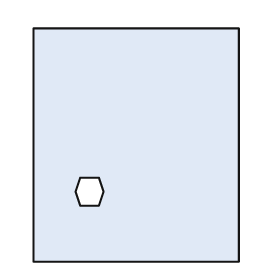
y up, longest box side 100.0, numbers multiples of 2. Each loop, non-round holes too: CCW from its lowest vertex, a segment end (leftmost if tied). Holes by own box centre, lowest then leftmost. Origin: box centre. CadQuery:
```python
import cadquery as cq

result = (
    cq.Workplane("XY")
    .moveTo(-44.0, -50.0)
    .lineTo(44.0, -50.0)
    .lineTo(44.0, 50.0)
    .lineTo(-44.0, 50.0)
    .close()
    .moveTo(-24.0, -26.0)
    .lineTo(-16.0, -26.0)
    .lineTo(-14.0, -20.0)
    .lineTo(-16.0, -14.0)
    .lineTo(-24.0, -14.0)
    .lineTo(-26.0, -20.0)
    .close()
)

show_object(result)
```